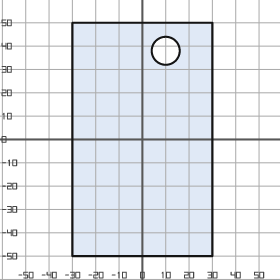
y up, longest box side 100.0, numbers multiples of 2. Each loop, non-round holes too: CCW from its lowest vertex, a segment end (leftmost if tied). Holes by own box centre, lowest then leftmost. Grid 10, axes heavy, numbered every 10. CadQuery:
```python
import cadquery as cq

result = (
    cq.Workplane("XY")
    .moveTo(-30.0, -50.0)
    .lineTo(30.0, -50.0)
    .lineTo(30.0, 50.0)
    .lineTo(-30.0, 50.0)
    .close()
    .moveTo(10.0, 38.0)
    .circle(6.0)
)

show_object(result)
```